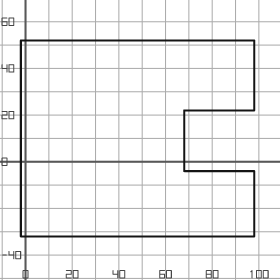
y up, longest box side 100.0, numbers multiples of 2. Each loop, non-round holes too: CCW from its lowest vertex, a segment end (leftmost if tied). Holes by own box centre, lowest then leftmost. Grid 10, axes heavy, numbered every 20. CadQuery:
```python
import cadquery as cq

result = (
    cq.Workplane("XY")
    .moveTo(-2.0, -32.0)
    .lineTo(98.0, -32.0)
    .lineTo(98.0, -4.0)
    .lineTo(68.0, -4.0)
    .lineTo(68.0, 22.0)
    .lineTo(98.0, 22.0)
    .lineTo(98.0, 52.0)
    .lineTo(-2.0, 52.0)
    .close()
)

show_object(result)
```